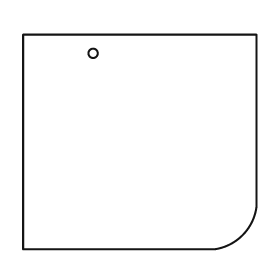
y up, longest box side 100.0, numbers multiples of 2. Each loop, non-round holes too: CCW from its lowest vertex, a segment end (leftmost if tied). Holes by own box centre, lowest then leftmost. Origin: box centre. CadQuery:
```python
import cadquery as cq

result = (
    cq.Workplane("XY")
    .moveTo(-50.0, -46.0)
    .lineTo(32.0, -46.0)
    .threePointArc((44.0, -40.0), (50.0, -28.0))
    .lineTo(50.0, 46.0)
    .lineTo(-50.0, 46.0)
    .close()
    .moveTo(-20.0, 38.0)
    .circle(2.0)
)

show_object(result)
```